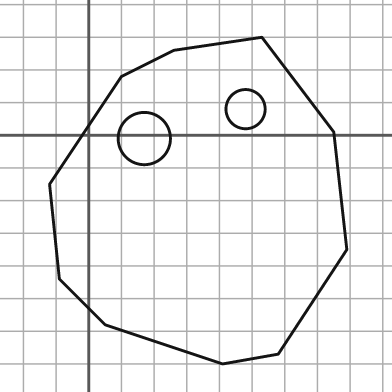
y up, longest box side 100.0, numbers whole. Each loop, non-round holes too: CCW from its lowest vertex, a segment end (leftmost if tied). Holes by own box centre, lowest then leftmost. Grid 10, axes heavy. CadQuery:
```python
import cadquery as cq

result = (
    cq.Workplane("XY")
    .moveTo(41.0, -70.0)
    .lineTo(58.0, -67.0)
    .lineTo(79.0, -35.0)
    .lineTo(75.0, 1.0)
    .lineTo(53.0, 30.0)
    .lineTo(26.0, 26.0)
    .lineTo(10.0, 18.0)
    .lineTo(-12.0, -15.0)
    .lineTo(-9.0, -44.0)
    .lineTo(5.0, -58.0)
    .close()
    .moveTo(17.0, -1.0)
    .circle(8.0)
    .moveTo(48.0, 8.0)
    .circle(6.0)
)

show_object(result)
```